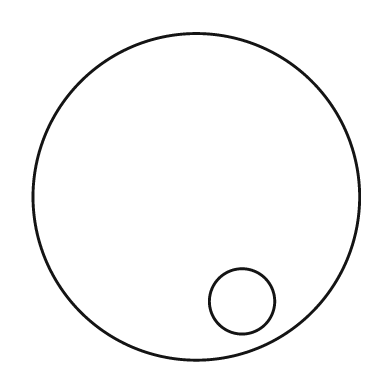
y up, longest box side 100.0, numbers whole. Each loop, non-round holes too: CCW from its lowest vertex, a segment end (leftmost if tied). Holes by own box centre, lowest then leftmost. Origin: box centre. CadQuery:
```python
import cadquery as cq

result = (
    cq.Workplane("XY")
    .moveTo(0.0, 0.0)
    .circle(50.0)
    .moveTo(14.0, -32.0)
    .circle(10.0)
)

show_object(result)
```